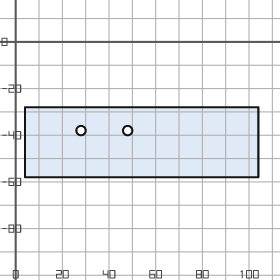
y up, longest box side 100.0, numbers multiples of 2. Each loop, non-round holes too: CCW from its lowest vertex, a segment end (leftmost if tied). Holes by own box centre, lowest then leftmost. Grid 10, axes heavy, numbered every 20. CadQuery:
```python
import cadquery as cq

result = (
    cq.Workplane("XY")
    .moveTo(4.0, -58.0)
    .lineTo(104.0, -58.0)
    .lineTo(104.0, -28.0)
    .lineTo(4.0, -28.0)
    .close()
    .moveTo(28.0, -38.0)
    .circle(2.0)
    .moveTo(48.0, -38.0)
    .circle(2.0)
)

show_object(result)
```